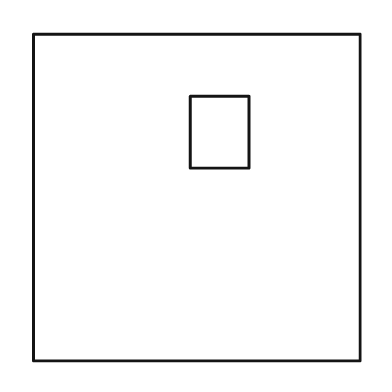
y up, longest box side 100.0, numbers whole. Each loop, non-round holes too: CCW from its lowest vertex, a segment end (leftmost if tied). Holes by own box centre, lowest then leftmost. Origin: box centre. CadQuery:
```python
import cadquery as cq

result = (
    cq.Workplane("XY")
    .moveTo(-50.0, -50.0)
    .lineTo(50.0, -50.0)
    .lineTo(50.0, 50.0)
    .lineTo(-50.0, 50.0)
    .close()
    .moveTo(-2.0, 9.0)
    .lineTo(16.0, 9.0)
    .lineTo(16.0, 31.0)
    .lineTo(-2.0, 31.0)
    .close()
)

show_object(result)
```